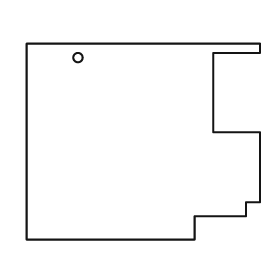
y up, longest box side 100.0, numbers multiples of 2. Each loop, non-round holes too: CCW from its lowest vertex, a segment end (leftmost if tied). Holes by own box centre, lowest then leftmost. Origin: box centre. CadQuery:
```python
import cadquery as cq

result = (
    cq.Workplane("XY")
    .moveTo(-50.0, -42.0)
    .lineTo(22.0, -42.0)
    .lineTo(22.0, -32.0)
    .lineTo(44.0, -32.0)
    .lineTo(44.0, -26.0)
    .lineTo(50.0, -26.0)
    .lineTo(50.0, 4.0)
    .lineTo(30.0, 4.0)
    .lineTo(30.0, 38.0)
    .lineTo(50.0, 38.0)
    .lineTo(50.0, 42.0)
    .lineTo(-50.0, 42.0)
    .close()
    .moveTo(-28.0, 36.0)
    .circle(2.0)
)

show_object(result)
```